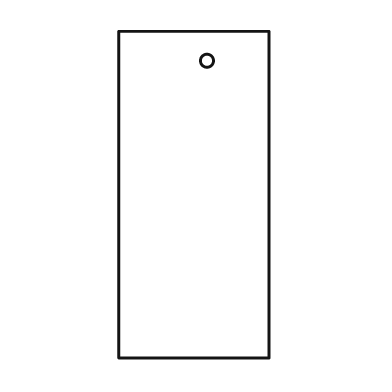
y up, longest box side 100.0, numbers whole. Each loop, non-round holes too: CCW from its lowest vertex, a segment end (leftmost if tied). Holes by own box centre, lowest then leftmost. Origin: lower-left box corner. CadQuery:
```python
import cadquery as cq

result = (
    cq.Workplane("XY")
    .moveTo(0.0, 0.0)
    .lineTo(46.0, 0.0)
    .lineTo(46.0, 100.0)
    .lineTo(0.0, 100.0)
    .close()
    .moveTo(27.0, 91.0)
    .circle(2.0)
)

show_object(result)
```